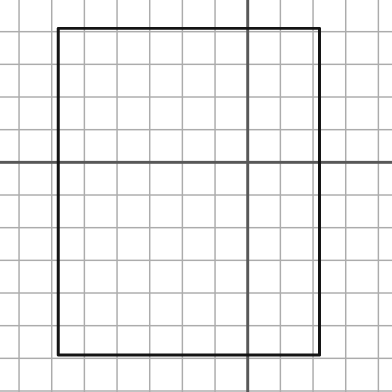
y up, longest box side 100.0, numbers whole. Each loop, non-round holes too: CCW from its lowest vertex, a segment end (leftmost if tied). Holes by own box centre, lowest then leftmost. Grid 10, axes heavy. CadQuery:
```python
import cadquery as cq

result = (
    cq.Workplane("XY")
    .moveTo(-58.0, -59.0)
    .lineTo(22.0, -59.0)
    .lineTo(22.0, 41.0)
    .lineTo(-58.0, 41.0)
    .close()
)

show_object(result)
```